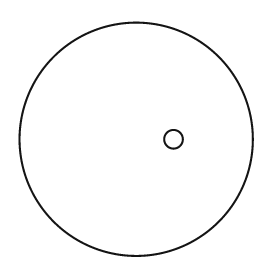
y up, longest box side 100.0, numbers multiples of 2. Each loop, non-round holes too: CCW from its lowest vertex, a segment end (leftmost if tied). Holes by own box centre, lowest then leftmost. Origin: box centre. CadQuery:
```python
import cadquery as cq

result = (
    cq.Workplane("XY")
    .moveTo(0.0, 0.0)
    .circle(50.0)
    .moveTo(16.0, 0.0)
    .circle(4.0)
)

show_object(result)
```